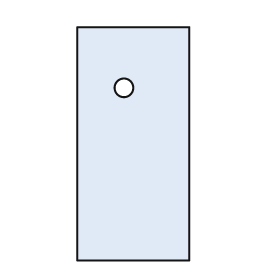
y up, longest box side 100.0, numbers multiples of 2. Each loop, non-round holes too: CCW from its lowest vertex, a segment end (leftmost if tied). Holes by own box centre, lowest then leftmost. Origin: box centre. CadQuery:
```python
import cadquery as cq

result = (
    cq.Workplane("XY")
    .moveTo(-24.0, -50.0)
    .lineTo(24.0, -50.0)
    .lineTo(24.0, 50.0)
    .lineTo(-24.0, 50.0)
    .close()
    .moveTo(-4.0, 24.0)
    .circle(4.0)
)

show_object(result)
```